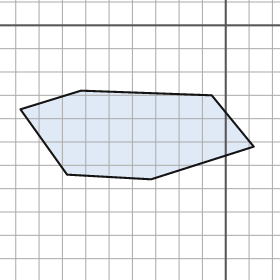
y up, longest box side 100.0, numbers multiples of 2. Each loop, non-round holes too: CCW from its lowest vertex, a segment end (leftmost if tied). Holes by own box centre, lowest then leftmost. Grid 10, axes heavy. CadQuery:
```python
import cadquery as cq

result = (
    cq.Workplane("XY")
    .moveTo(-32.0, -66.0)
    .lineTo(12.0, -52.0)
    .lineTo(-6.0, -30.0)
    .lineTo(-62.0, -28.0)
    .lineTo(-88.0, -36.0)
    .lineTo(-68.0, -64.0)
    .close()
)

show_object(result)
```